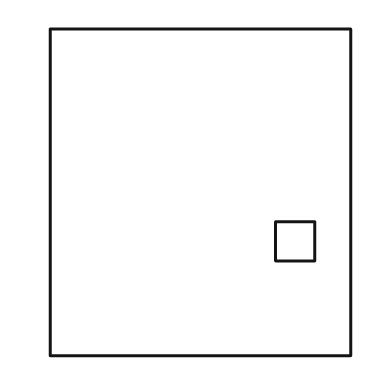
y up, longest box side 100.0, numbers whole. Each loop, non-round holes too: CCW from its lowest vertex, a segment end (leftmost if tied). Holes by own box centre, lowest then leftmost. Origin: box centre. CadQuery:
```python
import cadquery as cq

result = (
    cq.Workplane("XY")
    .moveTo(-46.0, -50.0)
    .lineTo(46.0, -50.0)
    .lineTo(46.0, 50.0)
    .lineTo(-46.0, 50.0)
    .close()
    .moveTo(23.0, -21.0)
    .lineTo(35.0, -21.0)
    .lineTo(35.0, -9.0)
    .lineTo(23.0, -9.0)
    .close()
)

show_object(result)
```